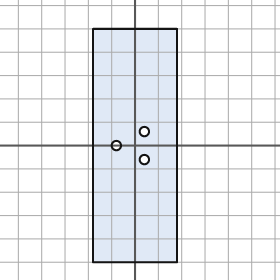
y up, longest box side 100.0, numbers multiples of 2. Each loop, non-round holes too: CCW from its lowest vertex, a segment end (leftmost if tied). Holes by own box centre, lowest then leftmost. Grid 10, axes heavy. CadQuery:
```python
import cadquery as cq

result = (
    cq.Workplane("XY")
    .moveTo(-18.0, -50.0)
    .lineTo(18.0, -50.0)
    .lineTo(18.0, 50.0)
    .lineTo(-18.0, 50.0)
    .close()
    .moveTo(4.0, -6.0)
    .circle(2.0)
    .moveTo(-8.0, 0.0)
    .circle(2.0)
    .moveTo(4.0, 6.0)
    .circle(2.0)
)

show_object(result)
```